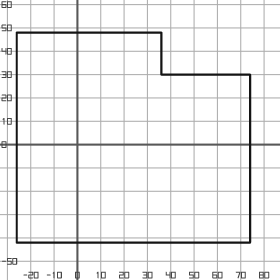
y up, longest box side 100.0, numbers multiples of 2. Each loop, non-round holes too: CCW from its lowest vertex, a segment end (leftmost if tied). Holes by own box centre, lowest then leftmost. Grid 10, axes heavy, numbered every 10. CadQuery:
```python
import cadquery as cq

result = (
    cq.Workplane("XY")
    .moveTo(-26.0, -42.0)
    .lineTo(74.0, -42.0)
    .lineTo(74.0, 30.0)
    .lineTo(36.0, 30.0)
    .lineTo(36.0, 48.0)
    .lineTo(-26.0, 48.0)
    .close()
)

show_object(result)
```